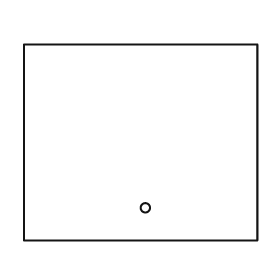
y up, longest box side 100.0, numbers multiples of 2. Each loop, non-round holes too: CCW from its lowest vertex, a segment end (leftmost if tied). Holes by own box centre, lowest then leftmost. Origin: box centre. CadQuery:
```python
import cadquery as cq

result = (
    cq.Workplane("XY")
    .moveTo(-50.0, -42.0)
    .lineTo(50.0, -42.0)
    .lineTo(50.0, 42.0)
    .lineTo(-50.0, 42.0)
    .close()
    .moveTo(2.0, -28.0)
    .circle(2.0)
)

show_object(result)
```